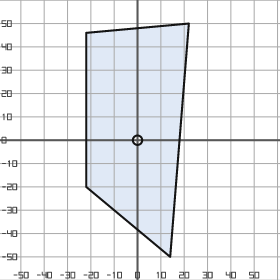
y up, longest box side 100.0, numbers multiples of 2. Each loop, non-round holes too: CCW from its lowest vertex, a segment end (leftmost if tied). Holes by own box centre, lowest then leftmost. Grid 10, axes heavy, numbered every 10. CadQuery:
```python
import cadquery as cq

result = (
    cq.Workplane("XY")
    .moveTo(14.0, -50.0)
    .lineTo(22.0, 50.0)
    .lineTo(-22.0, 46.0)
    .lineTo(-22.0, -20.0)
    .close()
    .moveTo(0.0, 0.0)
    .circle(2.0)
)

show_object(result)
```